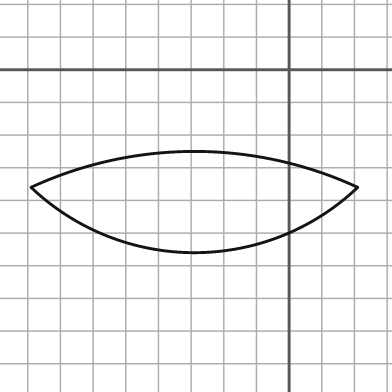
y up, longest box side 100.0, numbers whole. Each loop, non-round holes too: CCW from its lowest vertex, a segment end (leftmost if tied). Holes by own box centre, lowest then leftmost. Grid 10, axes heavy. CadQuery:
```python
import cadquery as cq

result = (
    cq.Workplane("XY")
    .moveTo(-79.0, -36.0)
    .threePointArc((-29.0, -56.0), (21.0, -36.0))
    .threePointArc((-29.0, -25.0), (-79.0, -36.0))
    .close()
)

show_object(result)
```